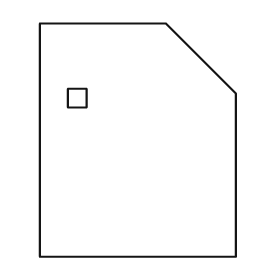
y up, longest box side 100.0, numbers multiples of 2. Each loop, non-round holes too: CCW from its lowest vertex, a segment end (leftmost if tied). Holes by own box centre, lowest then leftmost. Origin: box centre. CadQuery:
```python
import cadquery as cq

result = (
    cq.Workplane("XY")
    .moveTo(-42.0, -50.0)
    .lineTo(42.0, -50.0)
    .lineTo(42.0, 20.0)
    .lineTo(12.0, 50.0)
    .lineTo(-42.0, 50.0)
    .close()
    .moveTo(-30.0, 14.0)
    .lineTo(-22.0, 14.0)
    .lineTo(-22.0, 22.0)
    .lineTo(-30.0, 22.0)
    .close()
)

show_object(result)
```